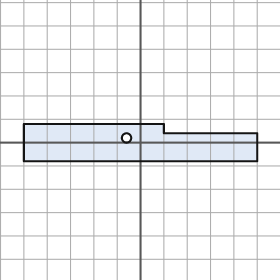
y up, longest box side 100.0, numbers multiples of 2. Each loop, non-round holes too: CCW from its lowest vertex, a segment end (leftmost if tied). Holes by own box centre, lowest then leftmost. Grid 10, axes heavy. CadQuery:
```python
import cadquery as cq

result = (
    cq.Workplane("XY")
    .moveTo(-50.0, -8.0)
    .lineTo(50.0, -8.0)
    .lineTo(50.0, 4.0)
    .lineTo(10.0, 4.0)
    .lineTo(10.0, 8.0)
    .lineTo(-50.0, 8.0)
    .close()
    .moveTo(-6.0, 2.0)
    .circle(2.0)
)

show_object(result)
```